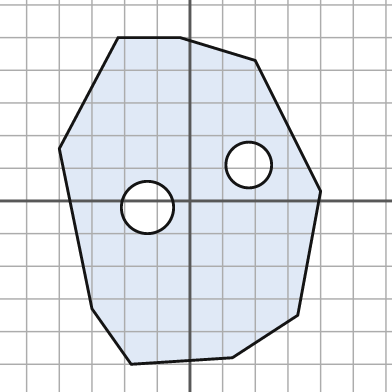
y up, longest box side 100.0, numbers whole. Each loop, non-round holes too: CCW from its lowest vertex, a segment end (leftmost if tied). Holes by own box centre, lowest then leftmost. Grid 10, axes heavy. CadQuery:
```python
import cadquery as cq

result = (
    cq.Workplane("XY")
    .moveTo(-18.0, -50.0)
    .lineTo(13.0, -48.0)
    .lineTo(33.0, -35.0)
    .lineTo(40.0, 3.0)
    .lineTo(20.0, 43.0)
    .lineTo(-3.0, 50.0)
    .lineTo(-22.0, 50.0)
    .lineTo(-40.0, 16.0)
    .lineTo(-30.0, -33.0)
    .close()
    .moveTo(-13.0, -2.0)
    .circle(8.0)
    .moveTo(18.0, 11.0)
    .circle(7.0)
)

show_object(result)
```